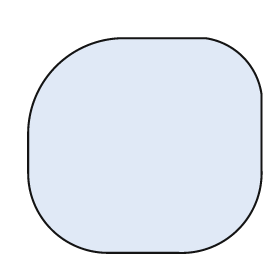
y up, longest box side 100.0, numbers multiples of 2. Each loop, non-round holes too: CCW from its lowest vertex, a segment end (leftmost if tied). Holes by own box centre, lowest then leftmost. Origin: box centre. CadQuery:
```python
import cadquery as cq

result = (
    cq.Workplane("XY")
    .moveTo(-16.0, -46.0)
    .lineTo(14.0, -46.0)
    .threePointArc((40.0, -36.0), (50.0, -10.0))
    .lineTo(50.0, 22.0)
    .threePointArc((42.0, 38.0), (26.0, 46.0))
    .lineTo(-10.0, 46.0)
    .threePointArc((-38.0, 34.0), (-50.0, 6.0))
    .lineTo(-50.0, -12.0)
    .threePointArc((-40.0, -36.0), (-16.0, -46.0))
    .close()
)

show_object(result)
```